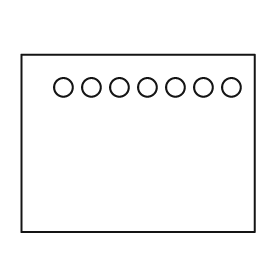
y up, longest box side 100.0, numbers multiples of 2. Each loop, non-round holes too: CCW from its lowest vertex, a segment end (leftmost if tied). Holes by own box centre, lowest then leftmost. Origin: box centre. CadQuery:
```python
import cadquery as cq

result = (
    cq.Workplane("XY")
    .moveTo(-50.0, -38.0)
    .lineTo(50.0, -38.0)
    .lineTo(50.0, 38.0)
    .lineTo(-50.0, 38.0)
    .close()
    .moveTo(-32.0, 24.0)
    .circle(4.0)
    .moveTo(-20.0, 24.0)
    .circle(4.0)
    .moveTo(-8.0, 24.0)
    .circle(4.0)
    .moveTo(4.0, 24.0)
    .circle(4.0)
    .moveTo(16.0, 24.0)
    .circle(4.0)
    .moveTo(28.0, 24.0)
    .circle(4.0)
    .moveTo(40.0, 24.0)
    .circle(4.0)
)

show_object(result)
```